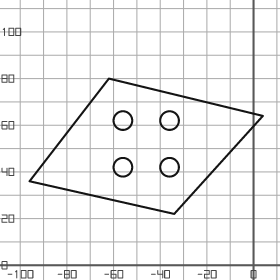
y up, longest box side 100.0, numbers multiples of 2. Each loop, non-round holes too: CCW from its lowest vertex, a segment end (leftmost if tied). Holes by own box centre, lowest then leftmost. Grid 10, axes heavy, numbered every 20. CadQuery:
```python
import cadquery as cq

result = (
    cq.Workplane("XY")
    .moveTo(-34.0, 22.0)
    .lineTo(4.0, 64.0)
    .lineTo(-62.0, 80.0)
    .lineTo(-96.0, 36.0)
    .close()
    .moveTo(-56.0, 42.0)
    .circle(4.0)
    .moveTo(-36.0, 42.0)
    .circle(4.0)
    .moveTo(-56.0, 62.0)
    .circle(4.0)
    .moveTo(-36.0, 62.0)
    .circle(4.0)
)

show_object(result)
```